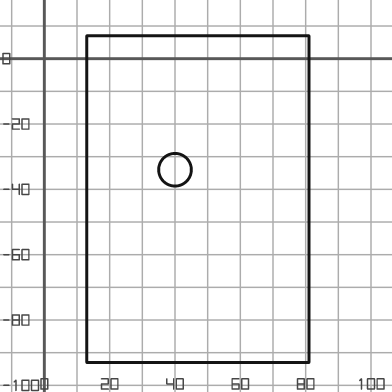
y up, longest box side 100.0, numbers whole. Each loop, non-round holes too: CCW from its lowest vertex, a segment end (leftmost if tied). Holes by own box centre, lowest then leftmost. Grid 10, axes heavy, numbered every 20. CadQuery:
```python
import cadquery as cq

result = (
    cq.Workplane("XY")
    .moveTo(13.0, -93.0)
    .lineTo(81.0, -93.0)
    .lineTo(81.0, 7.0)
    .lineTo(13.0, 7.0)
    .close()
    .moveTo(40.0, -34.0)
    .circle(5.0)
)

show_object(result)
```